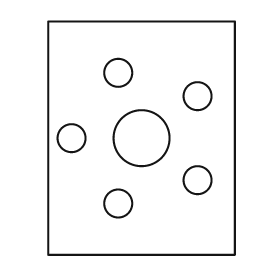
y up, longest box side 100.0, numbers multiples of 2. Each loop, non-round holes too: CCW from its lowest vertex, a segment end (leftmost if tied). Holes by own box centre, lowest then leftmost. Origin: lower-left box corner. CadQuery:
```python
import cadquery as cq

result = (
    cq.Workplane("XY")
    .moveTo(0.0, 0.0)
    .lineTo(80.0, 0.0)
    .lineTo(80.0, 100.0)
    .lineTo(0.0, 100.0)
    .close()
    .moveTo(30.0, 22.0)
    .circle(6.0)
    .moveTo(64.0, 32.0)
    .circle(6.0)
    .moveTo(10.0, 50.0)
    .circle(6.0)
    .moveTo(40.0, 50.0)
    .circle(12.0)
    .moveTo(64.0, 68.0)
    .circle(6.0)
    .moveTo(30.0, 78.0)
    .circle(6.0)
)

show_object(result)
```